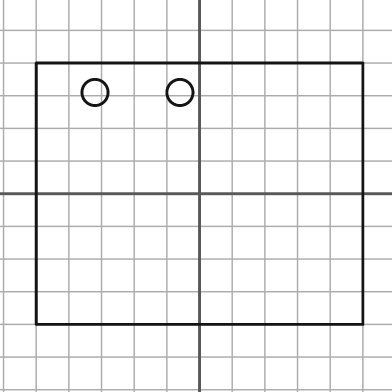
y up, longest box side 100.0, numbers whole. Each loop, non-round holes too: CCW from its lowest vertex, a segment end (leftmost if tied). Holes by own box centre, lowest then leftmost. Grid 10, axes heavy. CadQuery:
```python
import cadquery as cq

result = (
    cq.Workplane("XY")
    .moveTo(-50.0, -40.0)
    .lineTo(50.0, -40.0)
    .lineTo(50.0, 40.0)
    .lineTo(-50.0, 40.0)
    .close()
    .moveTo(-32.0, 31.0)
    .circle(4.0)
    .moveTo(-6.0, 31.0)
    .circle(4.0)
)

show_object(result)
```